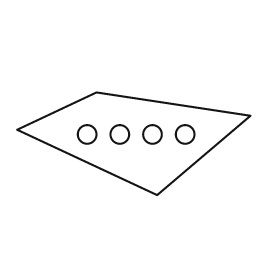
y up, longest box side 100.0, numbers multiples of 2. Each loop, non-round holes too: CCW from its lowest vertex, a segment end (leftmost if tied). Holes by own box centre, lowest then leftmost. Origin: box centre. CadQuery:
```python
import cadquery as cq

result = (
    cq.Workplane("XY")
    .moveTo(10.0, -22.0)
    .lineTo(50.0, 12.0)
    .lineTo(-16.0, 22.0)
    .lineTo(-50.0, 6.0)
    .close()
    .moveTo(-20.0, 4.0)
    .circle(4.0)
    .moveTo(-6.0, 4.0)
    .circle(4.0)
    .moveTo(8.0, 4.0)
    .circle(4.0)
    .moveTo(22.0, 4.0)
    .circle(4.0)
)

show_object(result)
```